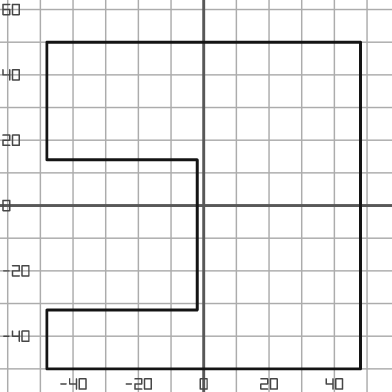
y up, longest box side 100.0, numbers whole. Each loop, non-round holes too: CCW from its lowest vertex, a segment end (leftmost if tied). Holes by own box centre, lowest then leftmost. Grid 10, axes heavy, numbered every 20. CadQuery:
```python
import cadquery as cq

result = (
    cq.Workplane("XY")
    .moveTo(-48.0, -50.0)
    .lineTo(48.0, -50.0)
    .lineTo(48.0, 50.0)
    .lineTo(-48.0, 50.0)
    .lineTo(-48.0, 14.0)
    .lineTo(-2.0, 14.0)
    .lineTo(-2.0, -32.0)
    .lineTo(-48.0, -32.0)
    .close()
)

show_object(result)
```